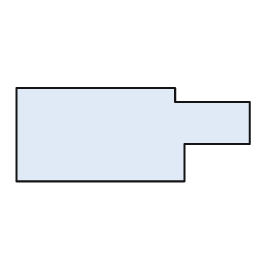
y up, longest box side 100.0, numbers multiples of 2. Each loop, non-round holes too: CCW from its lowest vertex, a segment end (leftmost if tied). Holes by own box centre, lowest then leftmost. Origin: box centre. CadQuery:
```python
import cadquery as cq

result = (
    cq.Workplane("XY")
    .moveTo(-50.0, -20.0)
    .lineTo(22.0, -20.0)
    .lineTo(22.0, -4.0)
    .lineTo(50.0, -4.0)
    .lineTo(50.0, 14.0)
    .lineTo(18.0, 14.0)
    .lineTo(18.0, 20.0)
    .lineTo(-50.0, 20.0)
    .close()
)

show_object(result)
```